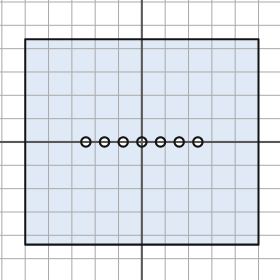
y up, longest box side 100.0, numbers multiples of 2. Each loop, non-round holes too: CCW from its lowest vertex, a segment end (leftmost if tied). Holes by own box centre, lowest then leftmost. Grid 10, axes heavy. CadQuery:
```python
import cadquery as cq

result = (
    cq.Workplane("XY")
    .moveTo(-50.0, -44.0)
    .lineTo(50.0, -44.0)
    .lineTo(50.0, 44.0)
    .lineTo(-50.0, 44.0)
    .close()
    .moveTo(-24.0, 0.0)
    .circle(2.0)
    .moveTo(-16.0, 0.0)
    .circle(2.0)
    .moveTo(-8.0, 0.0)
    .circle(2.0)
    .moveTo(0.0, 0.0)
    .circle(2.0)
    .moveTo(8.0, 0.0)
    .circle(2.0)
    .moveTo(16.0, 0.0)
    .circle(2.0)
    .moveTo(24.0, 0.0)
    .circle(2.0)
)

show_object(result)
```